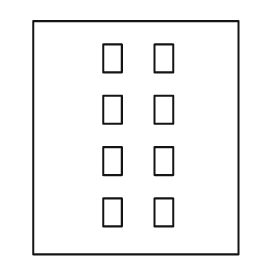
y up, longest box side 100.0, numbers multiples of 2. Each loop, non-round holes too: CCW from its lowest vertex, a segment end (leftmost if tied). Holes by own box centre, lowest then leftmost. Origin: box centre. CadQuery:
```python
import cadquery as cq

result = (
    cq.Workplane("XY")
    .moveTo(-44.0, -50.0)
    .lineTo(44.0, -50.0)
    .lineTo(44.0, 50.0)
    .lineTo(-44.0, 50.0)
    .close()
    .moveTo(-14.0, -38.0)
    .lineTo(-6.0, -38.0)
    .lineTo(-6.0, -26.0)
    .lineTo(-14.0, -26.0)
    .close()
    .moveTo(8.0, -38.0)
    .lineTo(16.0, -38.0)
    .lineTo(16.0, -26.0)
    .lineTo(8.0, -26.0)
    .close()
    .moveTo(-14.0, -16.0)
    .lineTo(-6.0, -16.0)
    .lineTo(-6.0, -4.0)
    .lineTo(-14.0, -4.0)
    .close()
    .moveTo(8.0, -16.0)
    .lineTo(16.0, -16.0)
    .lineTo(16.0, -4.0)
    .lineTo(8.0, -4.0)
    .close()
    .moveTo(-14.0, 6.0)
    .lineTo(-6.0, 6.0)
    .lineTo(-6.0, 18.0)
    .lineTo(-14.0, 18.0)
    .close()
    .moveTo(8.0, 6.0)
    .lineTo(16.0, 6.0)
    .lineTo(16.0, 18.0)
    .lineTo(8.0, 18.0)
    .close()
    .moveTo(-14.0, 28.0)
    .lineTo(-6.0, 28.0)
    .lineTo(-6.0, 40.0)
    .lineTo(-14.0, 40.0)
    .close()
    .moveTo(8.0, 28.0)
    .lineTo(16.0, 28.0)
    .lineTo(16.0, 40.0)
    .lineTo(8.0, 40.0)
    .close()
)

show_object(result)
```